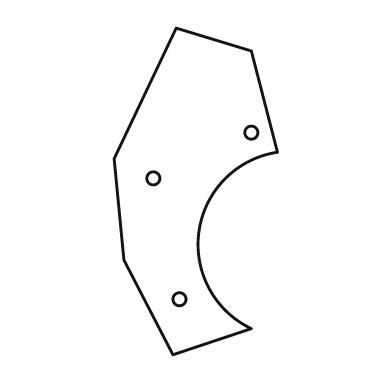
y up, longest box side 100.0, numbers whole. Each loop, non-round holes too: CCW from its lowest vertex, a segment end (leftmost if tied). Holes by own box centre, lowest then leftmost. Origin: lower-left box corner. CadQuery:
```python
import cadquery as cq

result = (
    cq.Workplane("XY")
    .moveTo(18.0, 0.0)
    .lineTo(42.0, 8.0)
    .threePointArc((26.0, 38.0), (50.0, 62.0))
    .lineTo(42.0, 93.0)
    .lineTo(19.0, 100.0)
    .lineTo(0.0, 60.0)
    .lineTo(3.0, 29.0)
    .close()
    .moveTo(20.0, 17.0)
    .circle(2.0)
    .moveTo(12.0, 54.0)
    .circle(2.0)
    .moveTo(42.0, 68.0)
    .circle(2.0)
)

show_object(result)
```